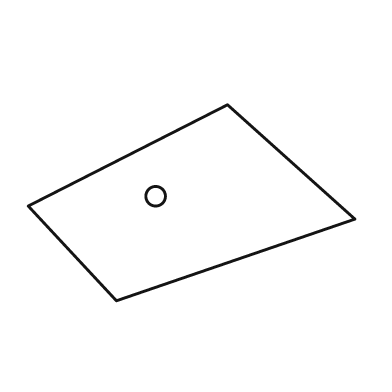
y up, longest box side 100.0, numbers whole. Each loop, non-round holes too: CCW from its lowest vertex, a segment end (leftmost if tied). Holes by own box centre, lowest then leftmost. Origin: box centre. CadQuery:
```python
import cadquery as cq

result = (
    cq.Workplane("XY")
    .moveTo(-23.0, -30.0)
    .lineTo(50.0, -5.0)
    .lineTo(11.0, 30.0)
    .lineTo(-50.0, -1.0)
    .close()
    .moveTo(-11.0, 2.0)
    .circle(3.0)
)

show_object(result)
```